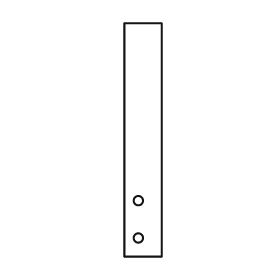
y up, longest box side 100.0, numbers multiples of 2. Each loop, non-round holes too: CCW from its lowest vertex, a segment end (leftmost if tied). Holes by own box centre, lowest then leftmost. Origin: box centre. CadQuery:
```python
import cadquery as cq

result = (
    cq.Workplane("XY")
    .moveTo(-8.0, -50.0)
    .lineTo(8.0, -50.0)
    .lineTo(8.0, 50.0)
    .lineTo(-8.0, 50.0)
    .close()
    .moveTo(-2.0, -42.0)
    .circle(2.0)
    .moveTo(-2.0, -26.0)
    .circle(2.0)
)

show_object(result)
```